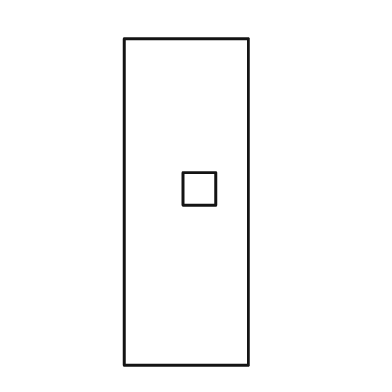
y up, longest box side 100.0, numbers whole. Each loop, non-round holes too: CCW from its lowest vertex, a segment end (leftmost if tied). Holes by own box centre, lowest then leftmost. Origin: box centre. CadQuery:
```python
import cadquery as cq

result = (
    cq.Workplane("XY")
    .moveTo(-19.0, -50.0)
    .lineTo(19.0, -50.0)
    .lineTo(19.0, 50.0)
    .lineTo(-19.0, 50.0)
    .close()
    .moveTo(-1.0, -1.0)
    .lineTo(9.0, -1.0)
    .lineTo(9.0, 9.0)
    .lineTo(-1.0, 9.0)
    .close()
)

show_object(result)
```